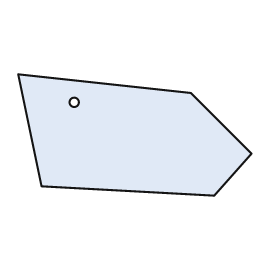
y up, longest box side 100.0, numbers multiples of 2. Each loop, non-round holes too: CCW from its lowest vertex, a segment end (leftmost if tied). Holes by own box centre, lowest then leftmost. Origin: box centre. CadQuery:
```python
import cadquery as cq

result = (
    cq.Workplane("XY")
    .moveTo(34.0, -26.0)
    .lineTo(50.0, -8.0)
    .lineTo(24.0, 18.0)
    .lineTo(-50.0, 26.0)
    .lineTo(-40.0, -22.0)
    .close()
    .moveTo(-26.0, 14.0)
    .circle(2.0)
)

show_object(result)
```